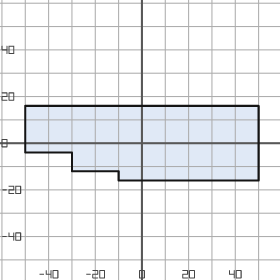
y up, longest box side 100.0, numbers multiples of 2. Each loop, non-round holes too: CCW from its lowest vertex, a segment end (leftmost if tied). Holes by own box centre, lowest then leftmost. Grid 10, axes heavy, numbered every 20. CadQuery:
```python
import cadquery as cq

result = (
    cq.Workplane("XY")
    .moveTo(-10.0, -16.0)
    .lineTo(50.0, -16.0)
    .lineTo(50.0, 16.0)
    .lineTo(-50.0, 16.0)
    .lineTo(-50.0, -4.0)
    .lineTo(-30.0, -4.0)
    .lineTo(-30.0, -12.0)
    .lineTo(-10.0, -12.0)
    .close()
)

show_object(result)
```